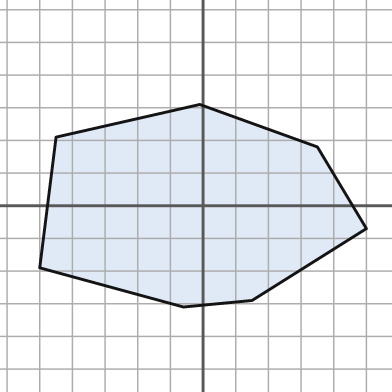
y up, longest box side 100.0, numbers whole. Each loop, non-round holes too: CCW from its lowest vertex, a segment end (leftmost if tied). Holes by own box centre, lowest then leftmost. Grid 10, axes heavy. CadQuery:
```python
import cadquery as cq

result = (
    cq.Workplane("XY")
    .moveTo(-6.0, -31.0)
    .lineTo(15.0, -29.0)
    .lineTo(50.0, -7.0)
    .lineTo(35.0, 18.0)
    .lineTo(-1.0, 31.0)
    .lineTo(-45.0, 21.0)
    .lineTo(-50.0, -19.0)
    .close()
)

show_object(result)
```